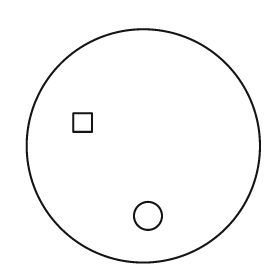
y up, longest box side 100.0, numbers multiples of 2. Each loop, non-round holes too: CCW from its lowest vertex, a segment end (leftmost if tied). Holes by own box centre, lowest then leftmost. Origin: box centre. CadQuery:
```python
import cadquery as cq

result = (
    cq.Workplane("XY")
    .moveTo(0.0, 0.0)
    .circle(50.0)
    .moveTo(2.0, -30.0)
    .circle(6.0)
    .moveTo(-30.0, 6.0)
    .lineTo(-22.0, 6.0)
    .lineTo(-22.0, 14.0)
    .lineTo(-30.0, 14.0)
    .close()
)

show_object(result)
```